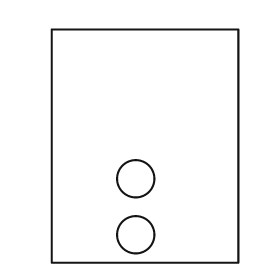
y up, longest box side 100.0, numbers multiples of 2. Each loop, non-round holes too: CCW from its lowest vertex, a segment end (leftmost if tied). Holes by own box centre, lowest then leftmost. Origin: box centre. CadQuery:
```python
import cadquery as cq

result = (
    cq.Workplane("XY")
    .moveTo(-40.0, -50.0)
    .lineTo(40.0, -50.0)
    .lineTo(40.0, 50.0)
    .lineTo(-40.0, 50.0)
    .close()
    .moveTo(-4.0, -38.0)
    .circle(8.0)
    .moveTo(-4.0, -14.0)
    .circle(8.0)
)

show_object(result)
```